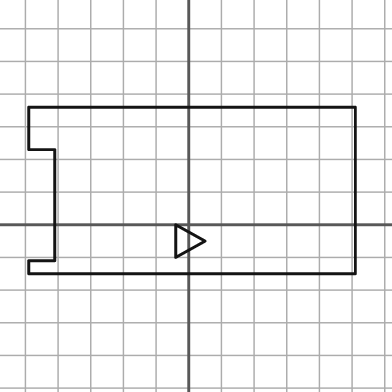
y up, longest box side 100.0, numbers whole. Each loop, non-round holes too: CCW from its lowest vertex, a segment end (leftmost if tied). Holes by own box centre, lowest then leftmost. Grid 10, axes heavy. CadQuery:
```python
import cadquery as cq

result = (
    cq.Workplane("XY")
    .moveTo(-49.0, -15.0)
    .lineTo(51.0, -15.0)
    .lineTo(51.0, 36.0)
    .lineTo(-49.0, 36.0)
    .lineTo(-49.0, 23.0)
    .lineTo(-41.0, 23.0)
    .lineTo(-41.0, -11.0)
    .lineTo(-49.0, -11.0)
    .close()
    .moveTo(-4.0, -10.0)
    .lineTo(5.0, -5.0)
    .lineTo(-4.0, 0.0)
    .close()
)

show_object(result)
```